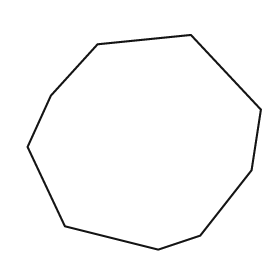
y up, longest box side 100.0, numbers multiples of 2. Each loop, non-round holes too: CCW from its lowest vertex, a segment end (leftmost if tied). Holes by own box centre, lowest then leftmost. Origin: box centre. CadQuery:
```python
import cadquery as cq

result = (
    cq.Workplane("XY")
    .moveTo(6.0, -46.0)
    .lineTo(24.0, -40.0)
    .lineTo(46.0, -12.0)
    .lineTo(50.0, 14.0)
    .lineTo(20.0, 46.0)
    .lineTo(-20.0, 42.0)
    .lineTo(-40.0, 20.0)
    .lineTo(-50.0, -2.0)
    .lineTo(-34.0, -36.0)
    .close()
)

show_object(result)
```